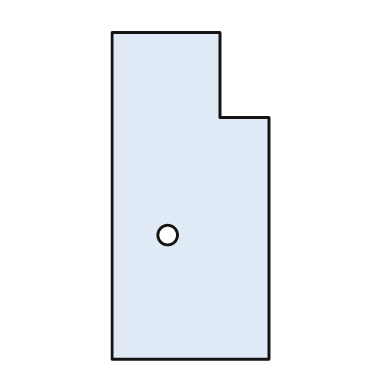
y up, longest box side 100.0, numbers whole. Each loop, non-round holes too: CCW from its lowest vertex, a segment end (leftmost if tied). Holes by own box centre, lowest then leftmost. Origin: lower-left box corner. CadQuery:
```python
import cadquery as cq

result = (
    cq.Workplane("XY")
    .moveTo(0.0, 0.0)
    .lineTo(48.0, 0.0)
    .lineTo(48.0, 74.0)
    .lineTo(33.0, 74.0)
    .lineTo(33.0, 100.0)
    .lineTo(0.0, 100.0)
    .close()
    .moveTo(17.0, 38.0)
    .circle(3.0)
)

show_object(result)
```